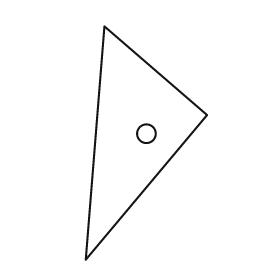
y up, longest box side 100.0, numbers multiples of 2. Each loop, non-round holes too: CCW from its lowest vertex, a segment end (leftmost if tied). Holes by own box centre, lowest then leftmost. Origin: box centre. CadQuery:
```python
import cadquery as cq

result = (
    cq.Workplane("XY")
    .moveTo(-26.0, -50.0)
    .lineTo(26.0, 12.0)
    .lineTo(-18.0, 50.0)
    .close()
    .moveTo(0.0, 4.0)
    .circle(4.0)
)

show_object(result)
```